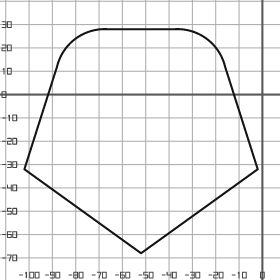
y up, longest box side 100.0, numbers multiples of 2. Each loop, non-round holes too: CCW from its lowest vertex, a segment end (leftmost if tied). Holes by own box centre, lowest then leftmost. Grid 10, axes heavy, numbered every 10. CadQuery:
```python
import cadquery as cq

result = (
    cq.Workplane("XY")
    .moveTo(-52.0, -68.0)
    .lineTo(-2.0, -32.0)
    .lineTo(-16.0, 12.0)
    .threePointArc((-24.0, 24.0), (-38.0, 28.0))
    .lineTo(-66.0, 28.0)
    .threePointArc((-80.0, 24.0), (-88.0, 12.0))
    .lineTo(-102.0, -32.0)
    .close()
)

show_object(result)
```